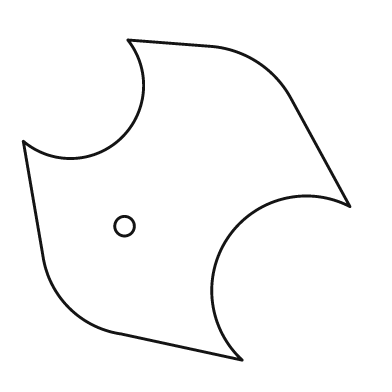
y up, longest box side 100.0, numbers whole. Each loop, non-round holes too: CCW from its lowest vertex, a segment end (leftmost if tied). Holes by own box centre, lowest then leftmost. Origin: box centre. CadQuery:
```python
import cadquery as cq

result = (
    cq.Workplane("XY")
    .moveTo(17.0, -49.0)
    .threePointArc((13.0, -11.0), (50.0, -2.0))
    .lineTo(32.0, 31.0)
    .threePointArc((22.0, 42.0), (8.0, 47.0))
    .lineTo(-18.0, 49.0)
    .threePointArc((-20.0, 19.0), (-50.0, 18.0))
    .lineTo(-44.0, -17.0)
    .threePointArc((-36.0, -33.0), (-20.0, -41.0))
    .close()
    .moveTo(-19.0, -8.0)
    .circle(3.0)
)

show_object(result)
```